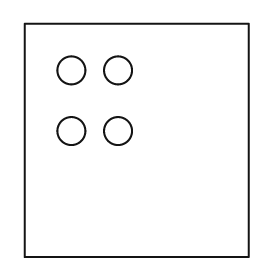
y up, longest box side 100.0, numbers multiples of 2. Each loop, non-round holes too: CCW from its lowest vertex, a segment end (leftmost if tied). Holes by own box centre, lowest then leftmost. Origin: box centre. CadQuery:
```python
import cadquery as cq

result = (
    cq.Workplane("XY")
    .moveTo(-48.0, -50.0)
    .lineTo(48.0, -50.0)
    .lineTo(48.0, 50.0)
    .lineTo(-48.0, 50.0)
    .close()
    .moveTo(-28.0, 4.0)
    .circle(6.0)
    .moveTo(-8.0, 4.0)
    .circle(6.0)
    .moveTo(-28.0, 30.0)
    .circle(6.0)
    .moveTo(-8.0, 30.0)
    .circle(6.0)
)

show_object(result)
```